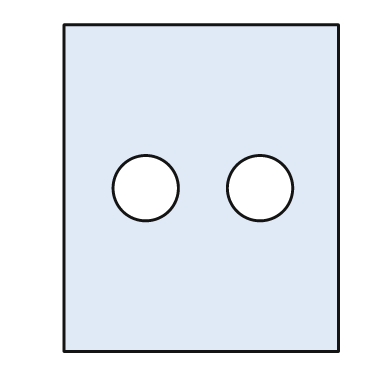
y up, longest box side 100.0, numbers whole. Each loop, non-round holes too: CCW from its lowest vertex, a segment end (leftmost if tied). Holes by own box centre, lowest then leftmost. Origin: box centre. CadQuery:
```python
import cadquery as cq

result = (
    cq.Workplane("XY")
    .moveTo(-42.0, -50.0)
    .lineTo(42.0, -50.0)
    .lineTo(42.0, 50.0)
    .lineTo(-42.0, 50.0)
    .close()
    .moveTo(-17.0, 0.0)
    .circle(10.0)
    .moveTo(18.0, 0.0)
    .circle(10.0)
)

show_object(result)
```